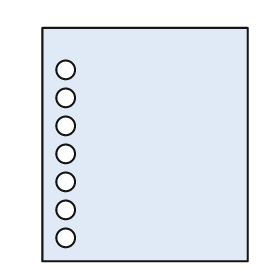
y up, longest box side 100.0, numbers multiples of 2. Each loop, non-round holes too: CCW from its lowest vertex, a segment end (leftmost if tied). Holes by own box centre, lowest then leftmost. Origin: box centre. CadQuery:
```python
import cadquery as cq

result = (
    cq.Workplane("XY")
    .moveTo(-44.0, -50.0)
    .lineTo(44.0, -50.0)
    .lineTo(44.0, 50.0)
    .lineTo(-44.0, 50.0)
    .close()
    .moveTo(-34.0, -40.0)
    .circle(4.0)
    .moveTo(-34.0, -28.0)
    .circle(4.0)
    .moveTo(-34.0, -16.0)
    .circle(4.0)
    .moveTo(-34.0, -4.0)
    .circle(4.0)
    .moveTo(-34.0, 8.0)
    .circle(4.0)
    .moveTo(-34.0, 20.0)
    .circle(4.0)
    .moveTo(-34.0, 32.0)
    .circle(4.0)
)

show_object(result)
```